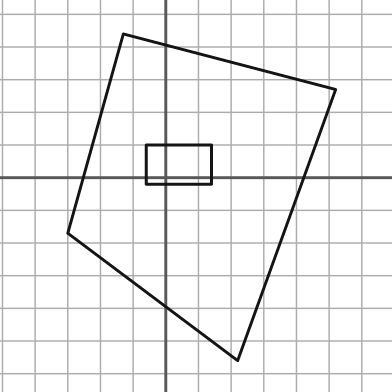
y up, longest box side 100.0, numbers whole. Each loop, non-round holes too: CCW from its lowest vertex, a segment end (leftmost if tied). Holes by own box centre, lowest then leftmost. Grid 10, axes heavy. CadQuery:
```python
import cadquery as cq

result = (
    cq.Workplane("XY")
    .moveTo(22.0, -56.0)
    .lineTo(52.0, 27.0)
    .lineTo(-13.0, 44.0)
    .lineTo(-30.0, -17.0)
    .close()
    .moveTo(-6.0, -2.0)
    .lineTo(14.0, -2.0)
    .lineTo(14.0, 10.0)
    .lineTo(-6.0, 10.0)
    .close()
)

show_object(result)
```